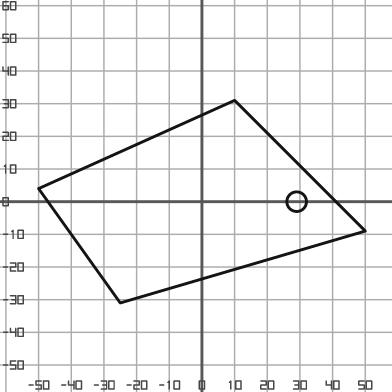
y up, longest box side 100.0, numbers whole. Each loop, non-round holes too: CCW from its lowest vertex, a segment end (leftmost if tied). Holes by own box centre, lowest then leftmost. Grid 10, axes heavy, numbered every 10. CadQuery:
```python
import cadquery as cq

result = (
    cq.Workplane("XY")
    .moveTo(-25.0, -31.0)
    .lineTo(50.0, -9.0)
    .lineTo(10.0, 31.0)
    .lineTo(-50.0, 4.0)
    .close()
    .moveTo(29.0, 0.0)
    .circle(3.0)
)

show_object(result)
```